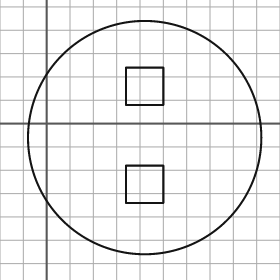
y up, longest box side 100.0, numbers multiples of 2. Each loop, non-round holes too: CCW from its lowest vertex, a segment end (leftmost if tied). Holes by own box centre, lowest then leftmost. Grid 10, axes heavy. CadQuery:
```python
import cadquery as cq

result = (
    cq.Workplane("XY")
    .moveTo(42.0, -6.0)
    .circle(50.0)
    .moveTo(34.0, -34.0)
    .lineTo(50.0, -34.0)
    .lineTo(50.0, -18.0)
    .lineTo(34.0, -18.0)
    .close()
    .moveTo(34.0, 8.0)
    .lineTo(50.0, 8.0)
    .lineTo(50.0, 24.0)
    .lineTo(34.0, 24.0)
    .close()
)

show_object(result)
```